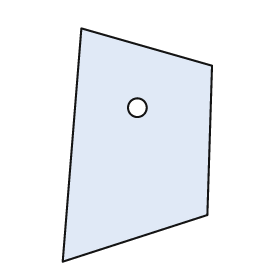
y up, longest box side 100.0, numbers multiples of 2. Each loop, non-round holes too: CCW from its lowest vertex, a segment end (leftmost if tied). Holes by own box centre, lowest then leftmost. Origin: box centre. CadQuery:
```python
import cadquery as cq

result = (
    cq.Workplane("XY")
    .moveTo(-32.0, -50.0)
    .lineTo(30.0, -30.0)
    .lineTo(32.0, 34.0)
    .lineTo(-24.0, 50.0)
    .close()
    .moveTo(0.0, 16.0)
    .circle(4.0)
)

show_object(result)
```